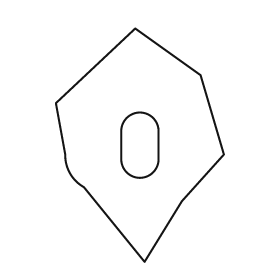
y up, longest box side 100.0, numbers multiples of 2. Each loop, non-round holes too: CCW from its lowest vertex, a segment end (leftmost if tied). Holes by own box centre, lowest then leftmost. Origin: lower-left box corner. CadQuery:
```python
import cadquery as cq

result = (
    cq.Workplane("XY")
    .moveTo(38.0, 0.0)
    .lineTo(54.0, 26.0)
    .lineTo(72.0, 46.0)
    .lineTo(62.0, 80.0)
    .lineTo(34.0, 100.0)
    .lineTo(0.0, 68.0)
    .lineTo(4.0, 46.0)
    .threePointArc((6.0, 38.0), (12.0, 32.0))
    .close()
    .moveTo(28.0, 44.0)
    .threePointArc((36.0, 36.0), (44.0, 44.0))
    .lineTo(44.0, 56.0)
    .threePointArc((36.0, 64.0), (28.0, 56.0))
    .close()
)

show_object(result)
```